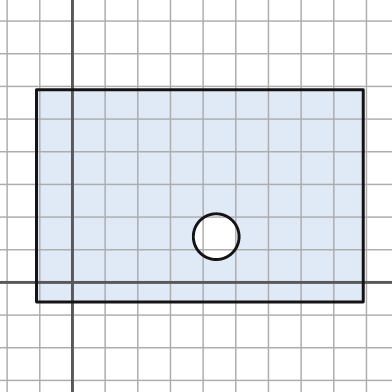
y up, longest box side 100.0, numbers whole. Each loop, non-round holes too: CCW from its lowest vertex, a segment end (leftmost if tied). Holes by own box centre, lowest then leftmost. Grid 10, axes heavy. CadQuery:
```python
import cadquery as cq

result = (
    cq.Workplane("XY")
    .moveTo(-11.0, -6.0)
    .lineTo(89.0, -6.0)
    .lineTo(89.0, 59.0)
    .lineTo(-11.0, 59.0)
    .close()
    .moveTo(44.0, 14.0)
    .circle(7.0)
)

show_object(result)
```